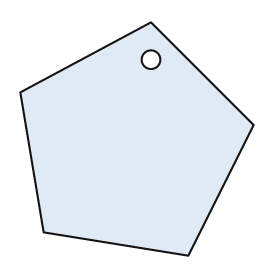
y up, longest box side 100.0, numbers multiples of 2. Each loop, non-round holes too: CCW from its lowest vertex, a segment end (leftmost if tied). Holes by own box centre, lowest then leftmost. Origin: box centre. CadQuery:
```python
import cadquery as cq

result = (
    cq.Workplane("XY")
    .moveTo(22.0, -50.0)
    .lineTo(50.0, 6.0)
    .lineTo(6.0, 50.0)
    .lineTo(-50.0, 20.0)
    .lineTo(-40.0, -40.0)
    .close()
    .moveTo(6.0, 34.0)
    .circle(4.0)
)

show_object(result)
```